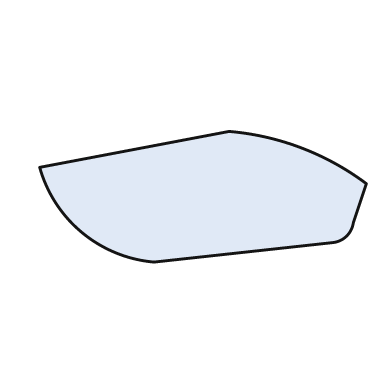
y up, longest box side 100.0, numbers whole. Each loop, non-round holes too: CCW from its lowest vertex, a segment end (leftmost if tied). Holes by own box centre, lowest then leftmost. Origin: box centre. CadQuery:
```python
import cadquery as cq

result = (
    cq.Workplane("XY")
    .moveTo(-15.0, -20.0)
    .lineTo(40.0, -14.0)
    .threePointArc((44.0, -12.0), (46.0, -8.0))
    .lineTo(50.0, 4.0)
    .threePointArc((30.0, 15.0), (8.0, 20.0))
    .lineTo(-50.0, 9.0)
    .threePointArc((-37.0, -11.0), (-15.0, -20.0))
    .close()
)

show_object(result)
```